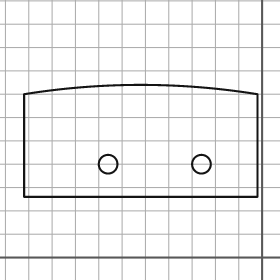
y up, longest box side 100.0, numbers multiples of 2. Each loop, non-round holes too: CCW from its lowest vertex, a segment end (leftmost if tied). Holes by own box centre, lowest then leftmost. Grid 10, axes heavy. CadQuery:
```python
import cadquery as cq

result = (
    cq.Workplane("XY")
    .moveTo(-102.0, 26.0)
    .lineTo(-2.0, 26.0)
    .lineTo(-2.0, 70.0)
    .threePointArc((-52.0, 74.0), (-102.0, 70.0))
    .close()
    .moveTo(-66.0, 40.0)
    .circle(4.0)
    .moveTo(-26.0, 40.0)
    .circle(4.0)
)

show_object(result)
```